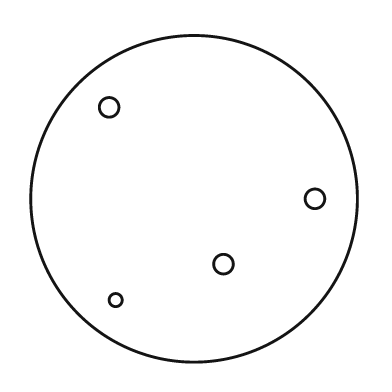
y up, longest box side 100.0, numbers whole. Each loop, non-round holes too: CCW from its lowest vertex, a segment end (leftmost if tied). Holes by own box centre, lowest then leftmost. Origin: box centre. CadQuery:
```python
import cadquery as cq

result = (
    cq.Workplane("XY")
    .moveTo(0.0, 0.0)
    .circle(50.0)
    .moveTo(-24.0, -31.0)
    .circle(2.0)
    .moveTo(9.0, -20.0)
    .circle(3.0)
    .moveTo(37.0, 0.0)
    .circle(3.0)
    .moveTo(-26.0, 28.0)
    .circle(3.0)
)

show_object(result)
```